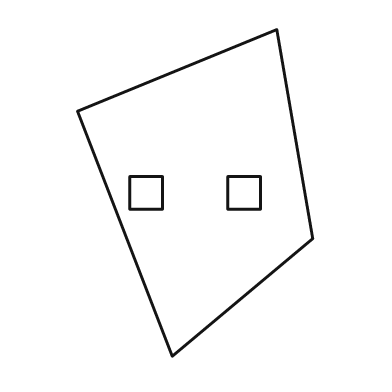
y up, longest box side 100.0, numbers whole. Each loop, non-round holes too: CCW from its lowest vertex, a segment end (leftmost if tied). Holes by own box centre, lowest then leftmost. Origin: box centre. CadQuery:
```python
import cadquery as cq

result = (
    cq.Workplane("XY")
    .moveTo(-7.0, -50.0)
    .lineTo(36.0, -14.0)
    .lineTo(25.0, 50.0)
    .lineTo(-36.0, 25.0)
    .close()
    .moveTo(-20.0, -5.0)
    .lineTo(-10.0, -5.0)
    .lineTo(-10.0, 5.0)
    .lineTo(-20.0, 5.0)
    .close()
    .moveTo(10.0, -5.0)
    .lineTo(20.0, -5.0)
    .lineTo(20.0, 5.0)
    .lineTo(10.0, 5.0)
    .close()
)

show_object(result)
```